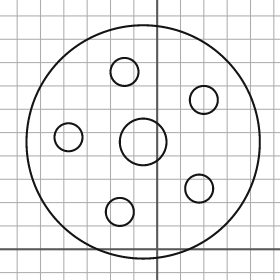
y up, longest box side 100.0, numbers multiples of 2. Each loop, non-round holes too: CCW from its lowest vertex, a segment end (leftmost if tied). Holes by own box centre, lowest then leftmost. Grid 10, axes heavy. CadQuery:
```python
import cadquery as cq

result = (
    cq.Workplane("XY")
    .moveTo(-6.0, 46.0)
    .circle(50.0)
    .moveTo(-16.0, 16.0)
    .circle(6.0)
    .moveTo(18.0, 26.0)
    .circle(6.0)
    .moveTo(-6.0, 46.0)
    .circle(10.0)
    .moveTo(-38.0, 48.0)
    .circle(6.0)
    .moveTo(20.0, 64.0)
    .circle(6.0)
    .moveTo(-14.0, 76.0)
    .circle(6.0)
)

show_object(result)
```